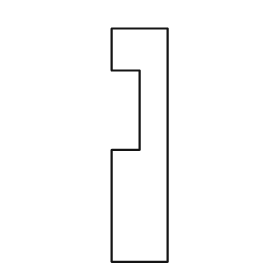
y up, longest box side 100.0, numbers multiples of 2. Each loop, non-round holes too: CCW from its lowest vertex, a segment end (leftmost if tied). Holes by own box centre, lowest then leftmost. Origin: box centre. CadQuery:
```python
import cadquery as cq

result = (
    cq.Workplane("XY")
    .moveTo(-12.0, -50.0)
    .lineTo(12.0, -50.0)
    .lineTo(12.0, 50.0)
    .lineTo(-12.0, 50.0)
    .lineTo(-12.0, 32.0)
    .lineTo(0.0, 32.0)
    .lineTo(0.0, -2.0)
    .lineTo(-12.0, -2.0)
    .close()
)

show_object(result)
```